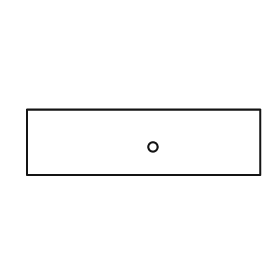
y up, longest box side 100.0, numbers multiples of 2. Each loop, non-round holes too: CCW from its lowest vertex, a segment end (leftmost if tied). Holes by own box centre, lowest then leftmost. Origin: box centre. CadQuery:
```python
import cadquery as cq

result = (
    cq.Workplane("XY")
    .moveTo(-50.0, -14.0)
    .lineTo(50.0, -14.0)
    .lineTo(50.0, 14.0)
    .lineTo(-50.0, 14.0)
    .close()
    .moveTo(4.0, -2.0)
    .circle(2.0)
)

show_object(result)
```